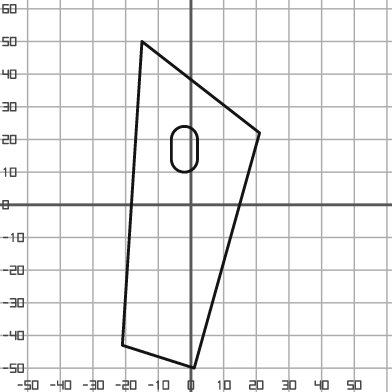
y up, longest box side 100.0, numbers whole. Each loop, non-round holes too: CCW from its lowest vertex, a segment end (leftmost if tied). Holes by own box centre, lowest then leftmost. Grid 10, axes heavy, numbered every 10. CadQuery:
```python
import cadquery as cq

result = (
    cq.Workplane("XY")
    .moveTo(1.0, -50.0)
    .lineTo(21.0, 22.0)
    .lineTo(-15.0, 50.0)
    .lineTo(-21.0, -43.0)
    .close()
    .moveTo(-6.0, 14.0)
    .threePointArc((-2.0, 10.0), (2.0, 14.0))
    .lineTo(2.0, 20.0)
    .threePointArc((-2.0, 24.0), (-6.0, 20.0))
    .close()
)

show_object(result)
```